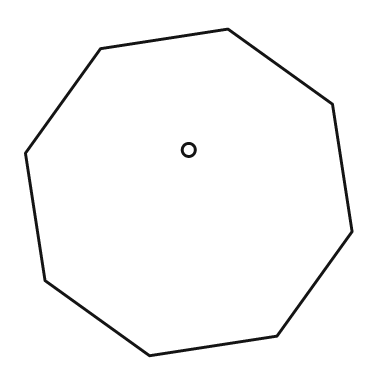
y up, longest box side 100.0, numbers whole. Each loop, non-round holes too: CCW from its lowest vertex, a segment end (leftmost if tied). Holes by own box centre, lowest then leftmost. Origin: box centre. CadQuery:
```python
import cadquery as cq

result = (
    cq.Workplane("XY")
    .moveTo(-12.0, -50.0)
    .lineTo(27.0, -44.0)
    .lineTo(50.0, -12.0)
    .lineTo(44.0, 27.0)
    .lineTo(12.0, 50.0)
    .lineTo(-27.0, 44.0)
    .lineTo(-50.0, 12.0)
    .lineTo(-44.0, -27.0)
    .close()
    .moveTo(0.0, 13.0)
    .circle(2.0)
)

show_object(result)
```